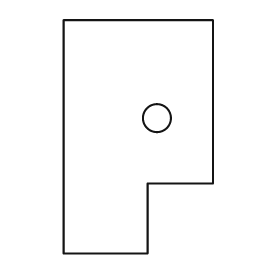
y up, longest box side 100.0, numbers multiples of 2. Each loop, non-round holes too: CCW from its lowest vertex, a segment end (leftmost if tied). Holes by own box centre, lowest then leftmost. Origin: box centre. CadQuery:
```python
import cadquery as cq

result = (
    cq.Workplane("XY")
    .moveTo(-32.0, -50.0)
    .lineTo(4.0, -50.0)
    .lineTo(4.0, -20.0)
    .lineTo(32.0, -20.0)
    .lineTo(32.0, 50.0)
    .lineTo(-32.0, 50.0)
    .close()
    .moveTo(8.0, 8.0)
    .circle(6.0)
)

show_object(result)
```